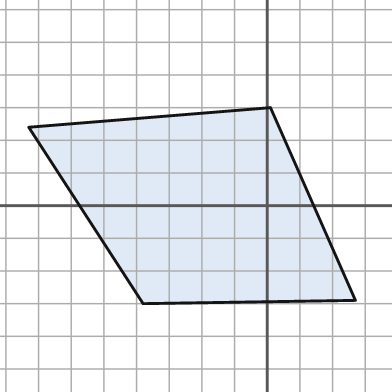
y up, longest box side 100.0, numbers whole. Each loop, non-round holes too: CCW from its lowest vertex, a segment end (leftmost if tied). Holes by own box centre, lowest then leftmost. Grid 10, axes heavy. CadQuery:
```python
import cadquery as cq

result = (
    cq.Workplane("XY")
    .moveTo(-38.0, -30.0)
    .lineTo(27.0, -29.0)
    .lineTo(1.0, 30.0)
    .lineTo(-73.0, 24.0)
    .close()
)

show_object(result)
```